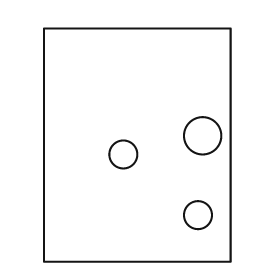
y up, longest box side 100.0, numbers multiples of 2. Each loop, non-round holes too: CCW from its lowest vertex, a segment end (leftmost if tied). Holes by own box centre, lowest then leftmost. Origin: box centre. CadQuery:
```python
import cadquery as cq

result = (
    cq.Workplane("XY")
    .moveTo(-40.0, -50.0)
    .lineTo(40.0, -50.0)
    .lineTo(40.0, 50.0)
    .lineTo(-40.0, 50.0)
    .close()
    .moveTo(26.0, -30.0)
    .circle(6.0)
    .moveTo(-6.0, -4.0)
    .circle(6.0)
    .moveTo(28.0, 4.0)
    .circle(8.0)
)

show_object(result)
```